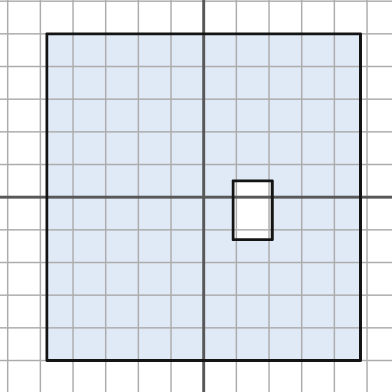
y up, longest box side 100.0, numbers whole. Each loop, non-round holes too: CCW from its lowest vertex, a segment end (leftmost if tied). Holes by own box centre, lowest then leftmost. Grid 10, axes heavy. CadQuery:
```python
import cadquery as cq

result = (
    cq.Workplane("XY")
    .moveTo(-48.0, -50.0)
    .lineTo(48.0, -50.0)
    .lineTo(48.0, 50.0)
    .lineTo(-48.0, 50.0)
    .close()
    .moveTo(9.0, -13.0)
    .lineTo(21.0, -13.0)
    .lineTo(21.0, 5.0)
    .lineTo(9.0, 5.0)
    .close()
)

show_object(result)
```